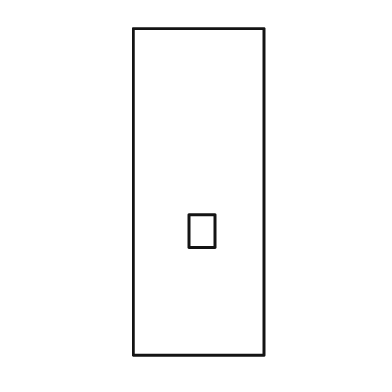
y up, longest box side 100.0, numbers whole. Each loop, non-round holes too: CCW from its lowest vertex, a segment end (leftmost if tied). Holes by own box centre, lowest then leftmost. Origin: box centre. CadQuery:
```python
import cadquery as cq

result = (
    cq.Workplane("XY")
    .moveTo(-20.0, -50.0)
    .lineTo(20.0, -50.0)
    .lineTo(20.0, 50.0)
    .lineTo(-20.0, 50.0)
    .close()
    .moveTo(-3.0, -17.0)
    .lineTo(5.0, -17.0)
    .lineTo(5.0, -7.0)
    .lineTo(-3.0, -7.0)
    .close()
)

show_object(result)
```